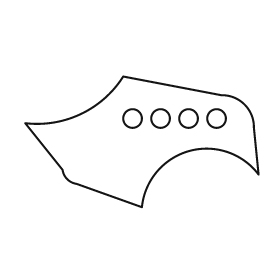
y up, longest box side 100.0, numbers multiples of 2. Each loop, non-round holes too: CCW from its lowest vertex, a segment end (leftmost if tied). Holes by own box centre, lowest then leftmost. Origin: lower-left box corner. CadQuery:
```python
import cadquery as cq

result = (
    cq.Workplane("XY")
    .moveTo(50.0, 0.0)
    .threePointArc((70.0, 24.0), (100.0, 14.0))
    .lineTo(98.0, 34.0)
    .threePointArc((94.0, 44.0), (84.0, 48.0))
    .lineTo(42.0, 56.0)
    .threePointArc((24.0, 40.0), (0.0, 36.0))
    .lineTo(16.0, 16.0)
    .threePointArc((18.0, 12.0), (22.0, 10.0))
    .close()
    .moveTo(46.0, 38.0)
    .circle(4.0)
    .moveTo(58.0, 38.0)
    .circle(4.0)
    .moveTo(70.0, 38.0)
    .circle(4.0)
    .moveTo(82.0, 38.0)
    .circle(4.0)
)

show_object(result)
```